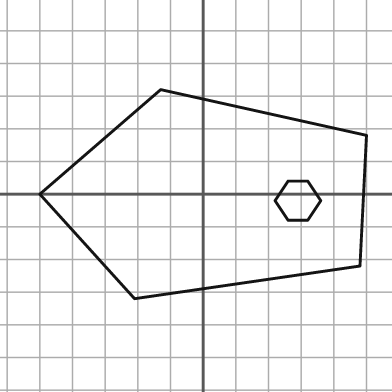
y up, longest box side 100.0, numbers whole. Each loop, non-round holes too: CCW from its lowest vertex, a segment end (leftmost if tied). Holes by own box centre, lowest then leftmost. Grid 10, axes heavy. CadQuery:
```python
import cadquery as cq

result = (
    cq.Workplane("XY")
    .moveTo(-21.0, -32.0)
    .lineTo(48.0, -22.0)
    .lineTo(50.0, 18.0)
    .lineTo(-13.0, 32.0)
    .lineTo(-50.0, 0.0)
    .close()
    .moveTo(26.0, -8.0)
    .lineTo(32.0, -8.0)
    .lineTo(36.0, -2.0)
    .lineTo(32.0, 4.0)
    .lineTo(26.0, 4.0)
    .lineTo(22.0, -2.0)
    .close()
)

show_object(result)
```